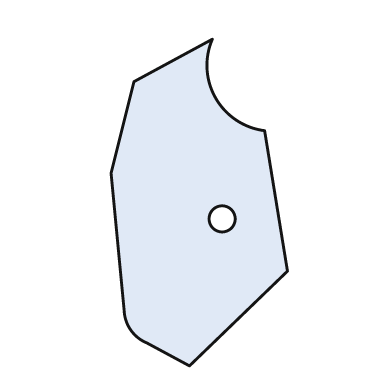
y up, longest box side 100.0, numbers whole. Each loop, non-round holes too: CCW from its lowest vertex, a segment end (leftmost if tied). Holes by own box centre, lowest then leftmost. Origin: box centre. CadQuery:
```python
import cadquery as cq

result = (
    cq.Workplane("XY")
    .moveTo(-3.0, -50.0)
    .lineTo(27.0, -21.0)
    .lineTo(20.0, 22.0)
    .threePointArc((5.0, 32.0), (4.0, 50.0))
    .lineTo(-20.0, 37.0)
    .lineTo(-27.0, 9.0)
    .lineTo(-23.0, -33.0)
    .threePointArc((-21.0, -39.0), (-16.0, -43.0))
    .close()
    .moveTo(7.0, -5.0)
    .circle(4.0)
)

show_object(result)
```